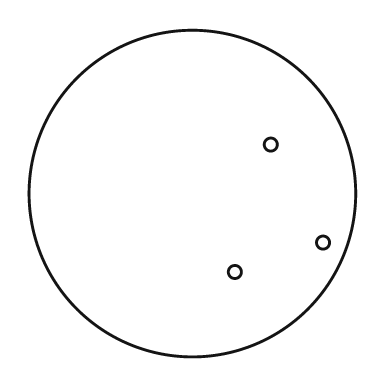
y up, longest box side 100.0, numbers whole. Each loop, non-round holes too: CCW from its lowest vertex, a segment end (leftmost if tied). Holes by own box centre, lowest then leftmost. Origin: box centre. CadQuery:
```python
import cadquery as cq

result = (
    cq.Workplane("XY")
    .moveTo(0.0, 0.0)
    .circle(50.0)
    .moveTo(13.0, -24.0)
    .circle(2.0)
    .moveTo(40.0, -15.0)
    .circle(2.0)
    .moveTo(24.0, 15.0)
    .circle(2.0)
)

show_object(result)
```